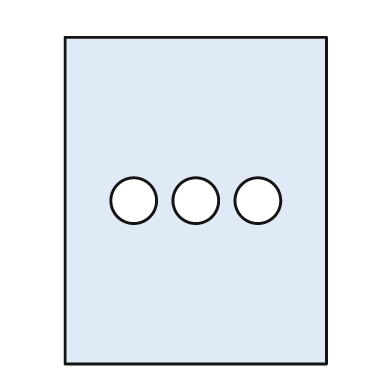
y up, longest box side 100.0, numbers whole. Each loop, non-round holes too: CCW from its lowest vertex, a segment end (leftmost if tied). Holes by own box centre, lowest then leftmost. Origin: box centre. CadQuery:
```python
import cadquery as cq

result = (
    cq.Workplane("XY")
    .moveTo(-40.0, -50.0)
    .lineTo(40.0, -50.0)
    .lineTo(40.0, 50.0)
    .lineTo(-40.0, 50.0)
    .close()
    .moveTo(-19.0, 0.0)
    .circle(7.0)
    .moveTo(0.0, 0.0)
    .circle(7.0)
    .moveTo(19.0, 0.0)
    .circle(7.0)
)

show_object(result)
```